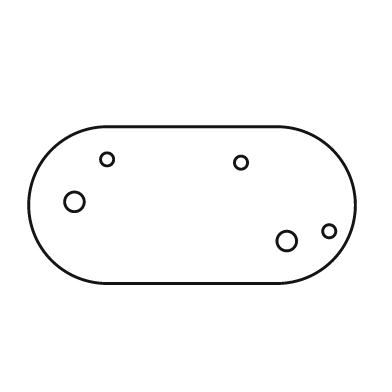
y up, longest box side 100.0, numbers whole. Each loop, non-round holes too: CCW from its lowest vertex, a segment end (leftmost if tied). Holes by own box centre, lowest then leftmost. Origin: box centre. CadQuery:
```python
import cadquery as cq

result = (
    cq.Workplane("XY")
    .moveTo(-26.0, -24.0)
    .lineTo(26.0, -24.0)
    .threePointArc((50.0, 0.0), (26.0, 24.0))
    .lineTo(-26.0, 24.0)
    .threePointArc((-50.0, 0.0), (-26.0, -24.0))
    .close()
    .moveTo(29.0, -11.0)
    .circle(3.0)
    .moveTo(42.0, -8.0)
    .circle(2.0)
    .moveTo(-36.0, 1.0)
    .circle(3.0)
    .moveTo(15.0, 13.0)
    .circle(2.0)
    .moveTo(-26.0, 14.0)
    .circle(2.0)
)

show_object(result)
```